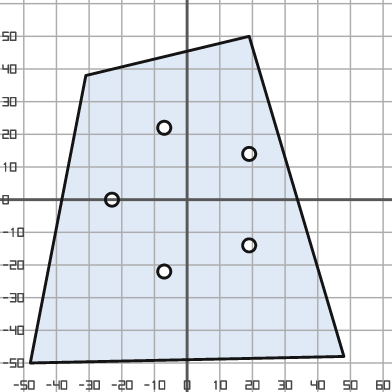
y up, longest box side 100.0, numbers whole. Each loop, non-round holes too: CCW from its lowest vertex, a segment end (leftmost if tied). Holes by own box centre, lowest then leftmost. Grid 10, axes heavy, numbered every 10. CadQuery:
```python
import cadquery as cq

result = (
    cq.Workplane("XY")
    .moveTo(-48.0, -50.0)
    .lineTo(48.0, -48.0)
    .lineTo(19.0, 50.0)
    .lineTo(-31.0, 38.0)
    .close()
    .moveTo(-7.0, -22.0)
    .circle(2.0)
    .moveTo(19.0, -14.0)
    .circle(2.0)
    .moveTo(-23.0, 0.0)
    .circle(2.0)
    .moveTo(19.0, 14.0)
    .circle(2.0)
    .moveTo(-7.0, 22.0)
    .circle(2.0)
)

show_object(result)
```